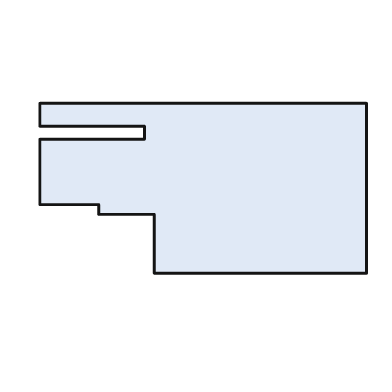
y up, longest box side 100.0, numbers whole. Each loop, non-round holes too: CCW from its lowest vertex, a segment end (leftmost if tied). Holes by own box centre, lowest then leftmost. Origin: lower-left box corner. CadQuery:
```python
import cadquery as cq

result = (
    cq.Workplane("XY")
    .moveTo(35.0, 0.0)
    .lineTo(100.0, 0.0)
    .lineTo(100.0, 52.0)
    .lineTo(0.0, 52.0)
    .lineTo(0.0, 45.0)
    .lineTo(32.0, 45.0)
    .lineTo(32.0, 41.0)
    .lineTo(0.0, 41.0)
    .lineTo(0.0, 21.0)
    .lineTo(18.0, 21.0)
    .lineTo(18.0, 18.0)
    .lineTo(35.0, 18.0)
    .close()
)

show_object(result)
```